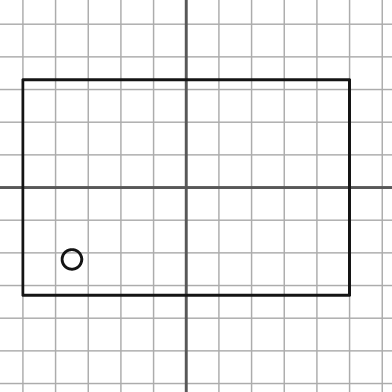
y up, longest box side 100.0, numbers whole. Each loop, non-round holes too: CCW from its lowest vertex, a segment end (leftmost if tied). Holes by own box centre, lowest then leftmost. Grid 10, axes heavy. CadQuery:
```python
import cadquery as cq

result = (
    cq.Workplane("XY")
    .moveTo(-50.0, -33.0)
    .lineTo(50.0, -33.0)
    .lineTo(50.0, 33.0)
    .lineTo(-50.0, 33.0)
    .close()
    .moveTo(-35.0, -22.0)
    .circle(3.0)
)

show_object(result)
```